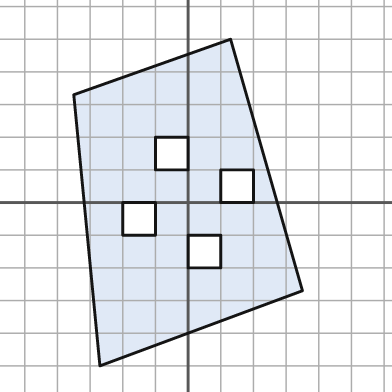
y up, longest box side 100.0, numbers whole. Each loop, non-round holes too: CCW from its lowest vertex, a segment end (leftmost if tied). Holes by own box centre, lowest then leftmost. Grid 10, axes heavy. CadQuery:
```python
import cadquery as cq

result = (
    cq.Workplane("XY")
    .moveTo(-27.0, -50.0)
    .lineTo(35.0, -27.0)
    .lineTo(13.0, 50.0)
    .lineTo(-35.0, 33.0)
    .close()
    .moveTo(0.0, -20.0)
    .lineTo(10.0, -20.0)
    .lineTo(10.0, -10.0)
    .lineTo(0.0, -10.0)
    .close()
    .moveTo(-20.0, -10.0)
    .lineTo(-10.0, -10.0)
    .lineTo(-10.0, 0.0)
    .lineTo(-20.0, 0.0)
    .close()
    .moveTo(10.0, 0.0)
    .lineTo(20.0, 0.0)
    .lineTo(20.0, 10.0)
    .lineTo(10.0, 10.0)
    .close()
    .moveTo(-10.0, 10.0)
    .lineTo(0.0, 10.0)
    .lineTo(0.0, 20.0)
    .lineTo(-10.0, 20.0)
    .close()
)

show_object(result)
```